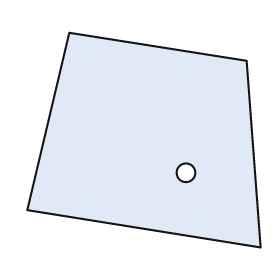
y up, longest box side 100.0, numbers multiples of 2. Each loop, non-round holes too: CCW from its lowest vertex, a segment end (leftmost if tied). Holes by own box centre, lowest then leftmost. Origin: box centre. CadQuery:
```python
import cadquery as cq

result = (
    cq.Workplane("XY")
    .moveTo(50.0, -46.0)
    .lineTo(44.0, 34.0)
    .lineTo(-32.0, 46.0)
    .lineTo(-50.0, -30.0)
    .close()
    .moveTo(18.0, -14.0)
    .circle(4.0)
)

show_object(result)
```